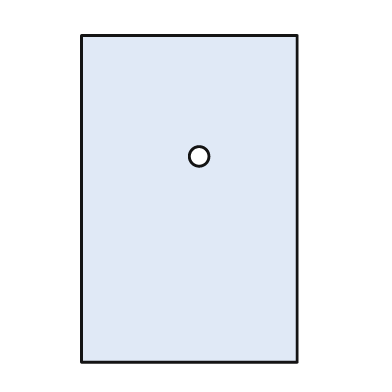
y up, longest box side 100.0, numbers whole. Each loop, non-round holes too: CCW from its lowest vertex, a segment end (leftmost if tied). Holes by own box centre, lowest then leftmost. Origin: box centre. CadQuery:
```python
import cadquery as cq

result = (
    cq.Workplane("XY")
    .moveTo(-33.0, -50.0)
    .lineTo(33.0, -50.0)
    .lineTo(33.0, 50.0)
    .lineTo(-33.0, 50.0)
    .close()
    .moveTo(3.0, 13.0)
    .circle(3.0)
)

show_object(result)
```